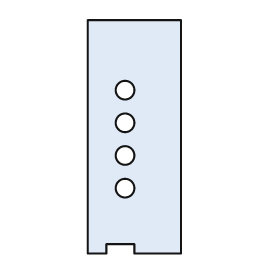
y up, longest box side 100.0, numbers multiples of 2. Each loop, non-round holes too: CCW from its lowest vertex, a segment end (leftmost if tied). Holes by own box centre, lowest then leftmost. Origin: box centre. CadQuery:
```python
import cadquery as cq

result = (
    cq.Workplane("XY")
    .moveTo(-20.0, -50.0)
    .lineTo(-12.0, -50.0)
    .lineTo(-12.0, -46.0)
    .lineTo(0.0, -46.0)
    .lineTo(0.0, -50.0)
    .lineTo(20.0, -50.0)
    .lineTo(20.0, 50.0)
    .lineTo(-20.0, 50.0)
    .close()
    .moveTo(-4.0, -22.0)
    .circle(4.0)
    .moveTo(-4.0, -8.0)
    .circle(4.0)
    .moveTo(-4.0, 6.0)
    .circle(4.0)
    .moveTo(-4.0, 20.0)
    .circle(4.0)
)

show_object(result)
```